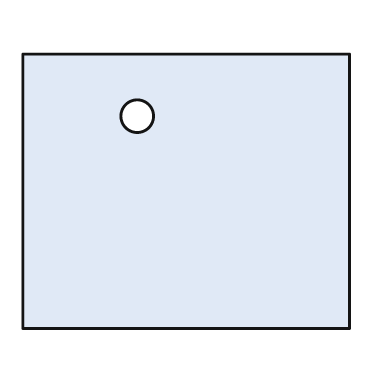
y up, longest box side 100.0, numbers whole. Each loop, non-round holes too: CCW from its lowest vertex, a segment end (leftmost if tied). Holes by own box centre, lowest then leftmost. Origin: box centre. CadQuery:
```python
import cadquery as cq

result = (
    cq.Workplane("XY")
    .moveTo(-50.0, -42.0)
    .lineTo(50.0, -42.0)
    .lineTo(50.0, 42.0)
    .lineTo(-50.0, 42.0)
    .close()
    .moveTo(-15.0, 23.0)
    .circle(5.0)
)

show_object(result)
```